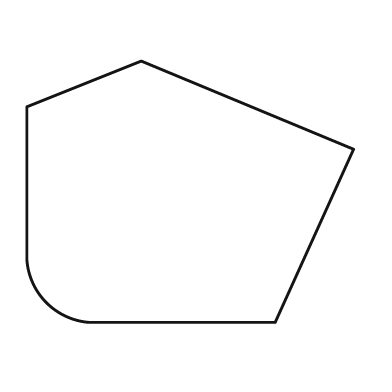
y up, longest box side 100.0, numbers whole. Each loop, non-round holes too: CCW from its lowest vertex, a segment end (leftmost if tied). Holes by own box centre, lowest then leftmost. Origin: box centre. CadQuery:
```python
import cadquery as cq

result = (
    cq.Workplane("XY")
    .moveTo(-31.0, -40.0)
    .lineTo(26.0, -40.0)
    .lineTo(50.0, 13.0)
    .lineTo(-15.0, 40.0)
    .lineTo(-50.0, 26.0)
    .lineTo(-50.0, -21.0)
    .threePointArc((-44.0, -34.0), (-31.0, -40.0))
    .close()
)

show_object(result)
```